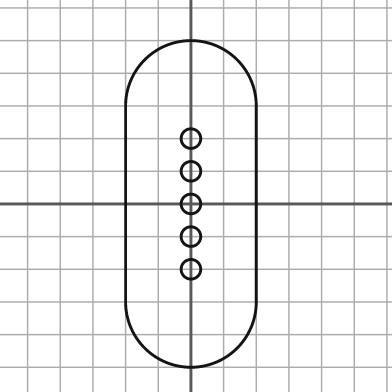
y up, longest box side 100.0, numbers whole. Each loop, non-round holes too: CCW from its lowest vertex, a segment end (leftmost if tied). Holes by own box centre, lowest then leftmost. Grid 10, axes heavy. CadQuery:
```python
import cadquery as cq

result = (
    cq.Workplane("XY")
    .moveTo(-20.0, -30.0)
    .threePointArc((0.0, -50.0), (20.0, -30.0))
    .lineTo(20.0, 30.0)
    .threePointArc((0.0, 50.0), (-20.0, 30.0))
    .close()
    .moveTo(0.0, -20.0)
    .circle(3.0)
    .moveTo(0.0, -10.0)
    .circle(3.0)
    .moveTo(0.0, 0.0)
    .circle(3.0)
    .moveTo(0.0, 10.0)
    .circle(3.0)
    .moveTo(0.0, 20.0)
    .circle(3.0)
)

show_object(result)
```